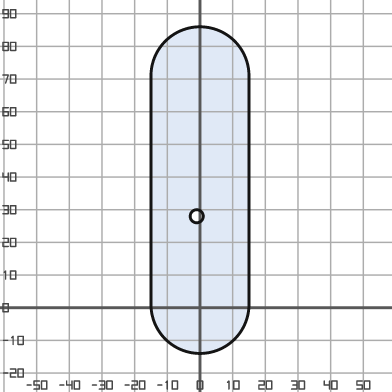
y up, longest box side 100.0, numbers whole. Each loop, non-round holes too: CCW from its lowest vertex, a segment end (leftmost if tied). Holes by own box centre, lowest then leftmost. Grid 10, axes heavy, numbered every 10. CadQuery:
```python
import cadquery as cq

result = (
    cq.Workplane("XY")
    .moveTo(-15.0, 1.0)
    .threePointArc((0.0, -14.0), (15.0, 1.0))
    .lineTo(15.0, 71.0)
    .threePointArc((0.0, 86.0), (-15.0, 71.0))
    .close()
    .moveTo(-1.0, 28.0)
    .circle(2.0)
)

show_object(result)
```